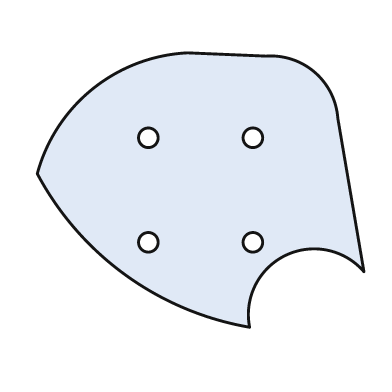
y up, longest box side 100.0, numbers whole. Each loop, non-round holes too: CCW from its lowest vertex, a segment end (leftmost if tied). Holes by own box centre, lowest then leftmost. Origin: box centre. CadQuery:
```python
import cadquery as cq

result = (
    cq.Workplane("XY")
    .moveTo(15.0, -42.0)
    .threePointArc((26.0, -20.0), (50.0, -25.0))
    .lineTo(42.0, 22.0)
    .threePointArc((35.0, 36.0), (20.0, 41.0))
    .lineTo(-4.0, 42.0)
    .threePointArc((-33.0, 31.0), (-50.0, 5.0))
    .threePointArc((-23.0, -26.0), (15.0, -42.0))
    .close()
    .moveTo(-16.0, -16.0)
    .circle(3.0)
    .moveTo(16.0, -16.0)
    .circle(3.0)
    .moveTo(-16.0, 16.0)
    .circle(3.0)
    .moveTo(16.0, 16.0)
    .circle(3.0)
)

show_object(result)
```